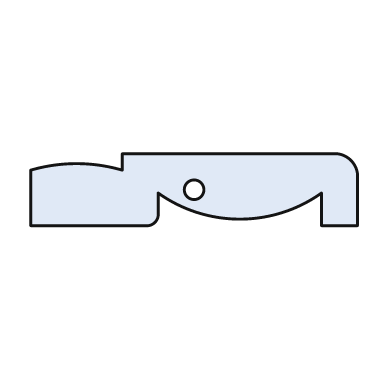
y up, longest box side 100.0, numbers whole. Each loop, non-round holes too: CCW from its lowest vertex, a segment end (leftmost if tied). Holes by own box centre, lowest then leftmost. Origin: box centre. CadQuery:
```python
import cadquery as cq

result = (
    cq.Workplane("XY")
    .moveTo(-50.0, -11.0)
    .lineTo(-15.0, -11.0)
    .threePointArc((-12.0, -10.0), (-11.0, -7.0))
    .lineTo(-11.0, -1.0)
    .threePointArc((14.0, -9.0), (39.0, -1.0))
    .lineTo(39.0, -11.0)
    .lineTo(50.0, -11.0)
    .lineTo(50.0, 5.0)
    .threePointArc((48.0, 9.0), (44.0, 11.0))
    .lineTo(-22.0, 11.0)
    .lineTo(-22.0, 6.0)
    .threePointArc((-36.0, 8.0), (-50.0, 6.0))
    .close()
    .moveTo(0.0, 0.0)
    .circle(3.0)
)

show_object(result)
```